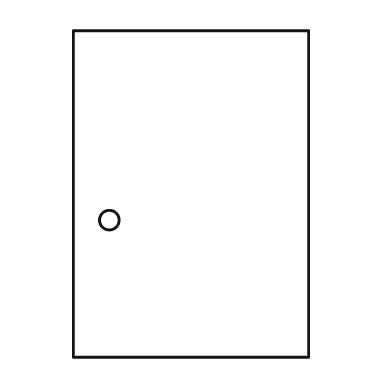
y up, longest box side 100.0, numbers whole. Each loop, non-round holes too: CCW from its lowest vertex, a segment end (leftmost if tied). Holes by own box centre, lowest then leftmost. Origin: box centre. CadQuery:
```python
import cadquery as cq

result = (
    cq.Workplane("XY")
    .moveTo(-36.0, -50.0)
    .lineTo(36.0, -50.0)
    .lineTo(36.0, 50.0)
    .lineTo(-36.0, 50.0)
    .close()
    .moveTo(-25.0, -8.0)
    .circle(3.0)
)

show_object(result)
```